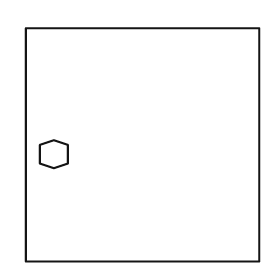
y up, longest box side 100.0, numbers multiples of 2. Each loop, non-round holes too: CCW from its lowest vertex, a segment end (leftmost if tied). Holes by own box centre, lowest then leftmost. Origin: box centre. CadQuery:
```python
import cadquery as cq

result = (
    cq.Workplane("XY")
    .moveTo(-50.0, -50.0)
    .lineTo(50.0, -50.0)
    .lineTo(50.0, 50.0)
    .lineTo(-50.0, 50.0)
    .close()
    .moveTo(-38.0, -10.0)
    .lineTo(-32.0, -8.0)
    .lineTo(-32.0, 0.0)
    .lineTo(-38.0, 2.0)
    .lineTo(-44.0, 0.0)
    .lineTo(-44.0, -8.0)
    .close()
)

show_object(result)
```